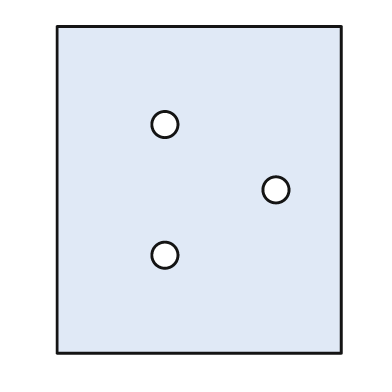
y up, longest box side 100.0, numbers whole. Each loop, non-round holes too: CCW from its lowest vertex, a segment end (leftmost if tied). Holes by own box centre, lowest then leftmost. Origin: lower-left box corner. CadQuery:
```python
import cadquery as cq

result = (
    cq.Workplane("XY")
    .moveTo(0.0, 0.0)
    .lineTo(87.0, 0.0)
    .lineTo(87.0, 100.0)
    .lineTo(0.0, 100.0)
    .close()
    .moveTo(33.0, 30.0)
    .circle(4.0)
    .moveTo(67.0, 50.0)
    .circle(4.0)
    .moveTo(33.0, 70.0)
    .circle(4.0)
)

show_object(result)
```